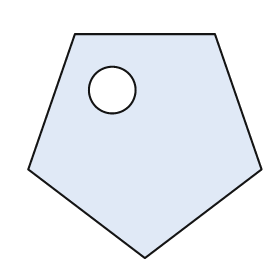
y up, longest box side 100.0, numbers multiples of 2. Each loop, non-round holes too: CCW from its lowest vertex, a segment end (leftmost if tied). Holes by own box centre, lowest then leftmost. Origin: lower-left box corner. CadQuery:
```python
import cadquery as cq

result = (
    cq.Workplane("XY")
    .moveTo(50.0, 0.0)
    .lineTo(100.0, 38.0)
    .lineTo(80.0, 96.0)
    .lineTo(20.0, 96.0)
    .lineTo(0.0, 38.0)
    .close()
    .moveTo(36.0, 72.0)
    .circle(10.0)
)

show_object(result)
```